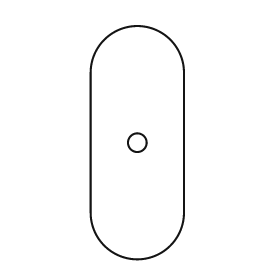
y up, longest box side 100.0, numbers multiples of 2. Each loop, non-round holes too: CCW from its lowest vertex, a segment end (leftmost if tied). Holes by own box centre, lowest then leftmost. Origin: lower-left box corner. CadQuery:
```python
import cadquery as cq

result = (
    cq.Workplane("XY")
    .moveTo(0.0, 20.0)
    .threePointArc((20.0, 0.0), (40.0, 20.0))
    .lineTo(40.0, 80.0)
    .threePointArc((20.0, 100.0), (0.0, 80.0))
    .close()
    .moveTo(20.0, 50.0)
    .circle(4.0)
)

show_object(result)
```